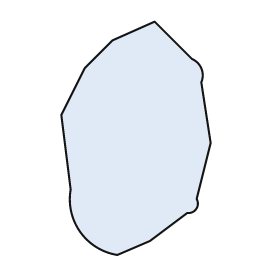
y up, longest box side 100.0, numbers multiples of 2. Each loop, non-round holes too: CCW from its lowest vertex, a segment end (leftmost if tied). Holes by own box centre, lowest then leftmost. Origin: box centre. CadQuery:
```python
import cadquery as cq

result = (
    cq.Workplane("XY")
    .moveTo(-8.0, -50.0)
    .lineTo(6.0, -44.0)
    .lineTo(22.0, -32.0)
    .threePointArc((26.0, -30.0), (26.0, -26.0))
    .lineTo(32.0, -2.0)
    .lineTo(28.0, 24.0)
    .threePointArc((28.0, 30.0), (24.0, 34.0))
    .lineTo(8.0, 50.0)
    .lineTo(-10.0, 42.0)
    .lineTo(-22.0, 30.0)
    .lineTo(-32.0, 10.0)
    .lineTo(-28.0, -22.0)
    .threePointArc((-24.0, -40.0), (-8.0, -50.0))
    .close()
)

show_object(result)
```